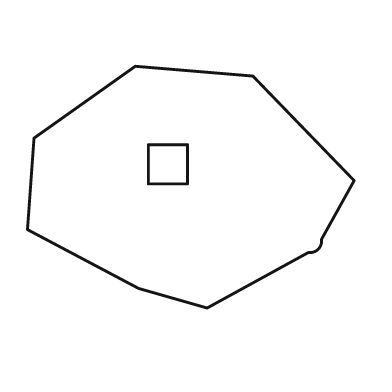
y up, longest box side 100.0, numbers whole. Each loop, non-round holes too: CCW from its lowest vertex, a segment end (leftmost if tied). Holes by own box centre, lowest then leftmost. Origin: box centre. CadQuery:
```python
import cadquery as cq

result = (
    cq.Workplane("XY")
    .moveTo(5.0, -37.0)
    .lineTo(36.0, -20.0)
    .threePointArc((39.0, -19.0), (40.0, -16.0))
    .lineTo(50.0, 2.0)
    .lineTo(19.0, 34.0)
    .lineTo(-17.0, 37.0)
    .lineTo(-48.0, 15.0)
    .lineTo(-50.0, -13.0)
    .lineTo(-16.0, -31.0)
    .close()
    .moveTo(-13.0, 1.0)
    .lineTo(-1.0, 1.0)
    .lineTo(-1.0, 13.0)
    .lineTo(-13.0, 13.0)
    .close()
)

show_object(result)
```